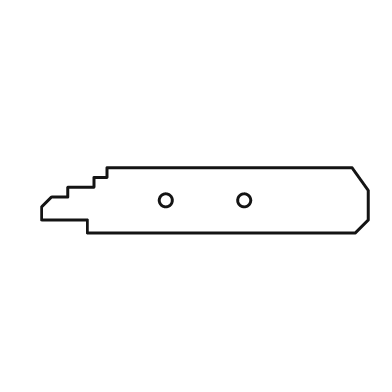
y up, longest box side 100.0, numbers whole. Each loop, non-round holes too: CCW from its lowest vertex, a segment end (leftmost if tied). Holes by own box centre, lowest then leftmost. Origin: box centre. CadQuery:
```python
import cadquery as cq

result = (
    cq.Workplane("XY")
    .moveTo(-36.0, -10.0)
    .lineTo(46.0, -10.0)
    .lineTo(50.0, -6.0)
    .lineTo(50.0, 3.0)
    .lineTo(45.0, 10.0)
    .lineTo(-30.0, 10.0)
    .lineTo(-30.0, 7.0)
    .lineTo(-34.0, 7.0)
    .lineTo(-34.0, 4.0)
    .lineTo(-42.0, 4.0)
    .lineTo(-42.0, 1.0)
    .lineTo(-47.0, 1.0)
    .lineTo(-50.0, -2.0)
    .lineTo(-50.0, -6.0)
    .lineTo(-36.0, -6.0)
    .close()
    .moveTo(-12.0, 0.0)
    .circle(2.0)
    .moveTo(12.0, 0.0)
    .circle(2.0)
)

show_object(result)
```